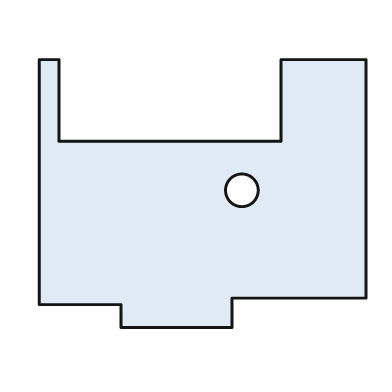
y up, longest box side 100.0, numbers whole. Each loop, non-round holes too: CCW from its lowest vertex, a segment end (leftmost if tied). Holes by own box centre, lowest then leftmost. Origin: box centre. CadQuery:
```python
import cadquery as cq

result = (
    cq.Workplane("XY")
    .moveTo(-25.0, -41.0)
    .lineTo(9.0, -41.0)
    .lineTo(9.0, -32.0)
    .lineTo(50.0, -32.0)
    .lineTo(50.0, 41.0)
    .lineTo(24.0, 41.0)
    .lineTo(24.0, 16.0)
    .lineTo(-44.0, 16.0)
    .lineTo(-44.0, 41.0)
    .lineTo(-50.0, 41.0)
    .lineTo(-50.0, -34.0)
    .lineTo(-25.0, -34.0)
    .close()
    .moveTo(12.0, 1.0)
    .circle(5.0)
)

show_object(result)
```